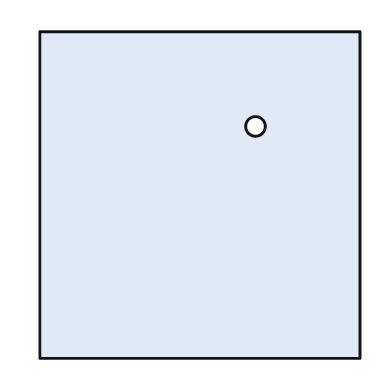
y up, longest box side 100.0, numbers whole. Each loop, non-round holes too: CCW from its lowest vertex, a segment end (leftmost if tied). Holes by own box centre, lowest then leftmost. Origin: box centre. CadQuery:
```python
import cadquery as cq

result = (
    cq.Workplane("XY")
    .moveTo(-49.0, -50.0)
    .lineTo(49.0, -50.0)
    .lineTo(49.0, 50.0)
    .lineTo(-49.0, 50.0)
    .close()
    .moveTo(17.0, 21.0)
    .circle(3.0)
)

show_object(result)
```